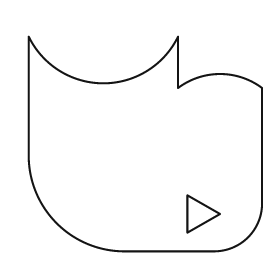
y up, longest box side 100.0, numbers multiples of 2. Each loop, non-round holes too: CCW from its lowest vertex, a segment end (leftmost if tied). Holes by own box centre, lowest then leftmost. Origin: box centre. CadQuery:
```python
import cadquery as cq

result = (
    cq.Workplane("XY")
    .moveTo(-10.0, -46.0)
    .lineTo(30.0, -46.0)
    .threePointArc((44.0, -40.0), (50.0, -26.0))
    .lineTo(50.0, 24.0)
    .threePointArc((32.0, 30.0), (14.0, 24.0))
    .lineTo(14.0, 46.0)
    .threePointArc((-18.0, 26.0), (-50.0, 46.0))
    .lineTo(-50.0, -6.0)
    .threePointArc((-38.0, -34.0), (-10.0, -46.0))
    .close()
    .moveTo(18.0, -38.0)
    .lineTo(32.0, -30.0)
    .lineTo(18.0, -22.0)
    .close()
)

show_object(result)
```